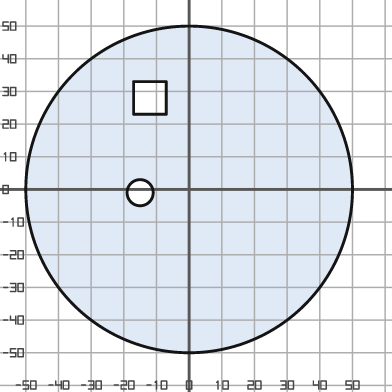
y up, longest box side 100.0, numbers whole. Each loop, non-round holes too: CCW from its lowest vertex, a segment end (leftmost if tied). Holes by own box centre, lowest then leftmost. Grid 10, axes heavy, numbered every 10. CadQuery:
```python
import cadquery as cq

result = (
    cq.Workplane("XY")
    .moveTo(0.0, 0.0)
    .circle(50.0)
    .moveTo(-15.0, -1.0)
    .circle(4.0)
    .moveTo(-17.0, 23.0)
    .lineTo(-7.0, 23.0)
    .lineTo(-7.0, 33.0)
    .lineTo(-17.0, 33.0)
    .close()
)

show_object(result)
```